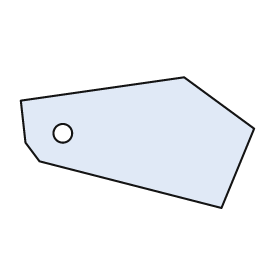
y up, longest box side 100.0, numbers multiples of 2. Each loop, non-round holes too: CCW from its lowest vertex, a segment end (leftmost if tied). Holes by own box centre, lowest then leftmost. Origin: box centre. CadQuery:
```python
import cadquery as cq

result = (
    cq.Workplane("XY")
    .moveTo(36.0, -28.0)
    .lineTo(50.0, 6.0)
    .lineTo(20.0, 28.0)
    .lineTo(-50.0, 18.0)
    .lineTo(-48.0, 0.0)
    .lineTo(-42.0, -8.0)
    .close()
    .moveTo(-32.0, 4.0)
    .circle(4.0)
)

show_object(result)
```